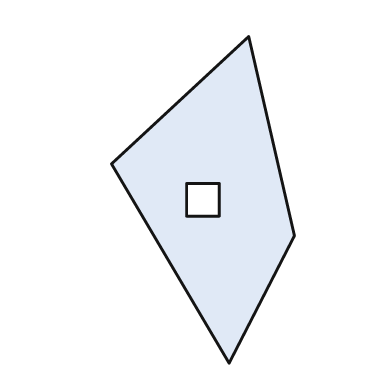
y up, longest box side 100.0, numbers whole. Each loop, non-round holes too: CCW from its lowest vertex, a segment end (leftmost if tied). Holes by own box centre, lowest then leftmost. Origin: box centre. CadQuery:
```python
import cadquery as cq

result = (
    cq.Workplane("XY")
    .moveTo(8.0, -50.0)
    .lineTo(28.0, -11.0)
    .lineTo(14.0, 50.0)
    .lineTo(-28.0, 11.0)
    .close()
    .moveTo(-5.0, -5.0)
    .lineTo(5.0, -5.0)
    .lineTo(5.0, 5.0)
    .lineTo(-5.0, 5.0)
    .close()
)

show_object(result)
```